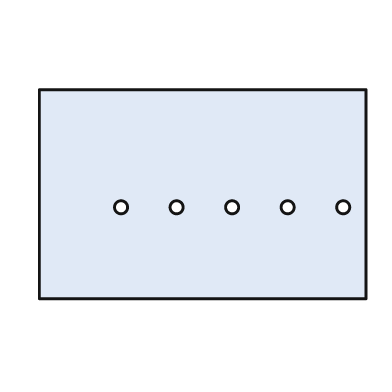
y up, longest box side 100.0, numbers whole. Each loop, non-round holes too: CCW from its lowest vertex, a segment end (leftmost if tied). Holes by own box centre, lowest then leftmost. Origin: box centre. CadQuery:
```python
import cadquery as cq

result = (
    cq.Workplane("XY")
    .moveTo(-50.0, -32.0)
    .lineTo(50.0, -32.0)
    .lineTo(50.0, 32.0)
    .lineTo(-50.0, 32.0)
    .close()
    .moveTo(-25.0, -4.0)
    .circle(2.0)
    .moveTo(-8.0, -4.0)
    .circle(2.0)
    .moveTo(9.0, -4.0)
    .circle(2.0)
    .moveTo(26.0, -4.0)
    .circle(2.0)
    .moveTo(43.0, -4.0)
    .circle(2.0)
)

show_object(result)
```